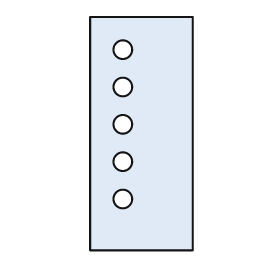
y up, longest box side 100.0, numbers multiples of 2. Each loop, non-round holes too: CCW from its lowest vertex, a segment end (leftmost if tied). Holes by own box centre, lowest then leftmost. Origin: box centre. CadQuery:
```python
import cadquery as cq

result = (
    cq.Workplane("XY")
    .moveTo(-22.0, -50.0)
    .lineTo(22.0, -50.0)
    .lineTo(22.0, 50.0)
    .lineTo(-22.0, 50.0)
    .close()
    .moveTo(-8.0, -28.0)
    .circle(4.0)
    .moveTo(-8.0, -12.0)
    .circle(4.0)
    .moveTo(-8.0, 4.0)
    .circle(4.0)
    .moveTo(-8.0, 20.0)
    .circle(4.0)
    .moveTo(-8.0, 36.0)
    .circle(4.0)
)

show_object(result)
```